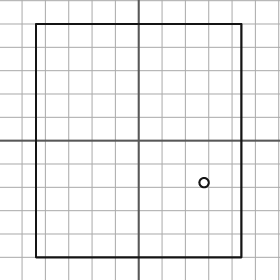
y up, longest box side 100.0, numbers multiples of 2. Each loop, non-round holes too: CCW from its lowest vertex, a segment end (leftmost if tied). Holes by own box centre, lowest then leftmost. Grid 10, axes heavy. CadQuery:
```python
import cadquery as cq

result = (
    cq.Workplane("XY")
    .moveTo(-44.0, -50.0)
    .lineTo(44.0, -50.0)
    .lineTo(44.0, 50.0)
    .lineTo(-44.0, 50.0)
    .close()
    .moveTo(28.0, -18.0)
    .circle(2.0)
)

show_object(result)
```